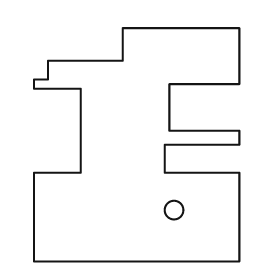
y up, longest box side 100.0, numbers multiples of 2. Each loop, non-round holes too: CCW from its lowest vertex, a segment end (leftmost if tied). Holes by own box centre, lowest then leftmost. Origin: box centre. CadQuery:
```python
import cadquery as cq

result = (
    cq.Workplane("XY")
    .moveTo(-44.0, -50.0)
    .lineTo(44.0, -50.0)
    .lineTo(44.0, -12.0)
    .lineTo(12.0, -12.0)
    .lineTo(12.0, 0.0)
    .lineTo(44.0, 0.0)
    .lineTo(44.0, 6.0)
    .lineTo(14.0, 6.0)
    .lineTo(14.0, 26.0)
    .lineTo(44.0, 26.0)
    .lineTo(44.0, 50.0)
    .lineTo(-6.0, 50.0)
    .lineTo(-6.0, 36.0)
    .lineTo(-38.0, 36.0)
    .lineTo(-38.0, 28.0)
    .lineTo(-44.0, 28.0)
    .lineTo(-44.0, 24.0)
    .lineTo(-24.0, 24.0)
    .lineTo(-24.0, -12.0)
    .lineTo(-44.0, -12.0)
    .close()
    .moveTo(16.0, -28.0)
    .circle(4.0)
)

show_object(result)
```